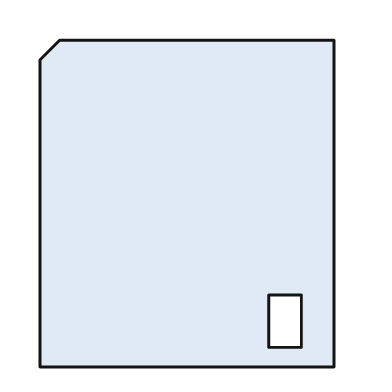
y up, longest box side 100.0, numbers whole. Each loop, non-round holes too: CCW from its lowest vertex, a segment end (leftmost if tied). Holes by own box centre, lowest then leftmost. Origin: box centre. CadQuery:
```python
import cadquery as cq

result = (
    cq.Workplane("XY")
    .moveTo(-45.0, -50.0)
    .lineTo(45.0, -50.0)
    .lineTo(45.0, 50.0)
    .lineTo(-39.0, 50.0)
    .lineTo(-45.0, 44.0)
    .close()
    .moveTo(25.0, -44.0)
    .lineTo(35.0, -44.0)
    .lineTo(35.0, -28.0)
    .lineTo(25.0, -28.0)
    .close()
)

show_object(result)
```